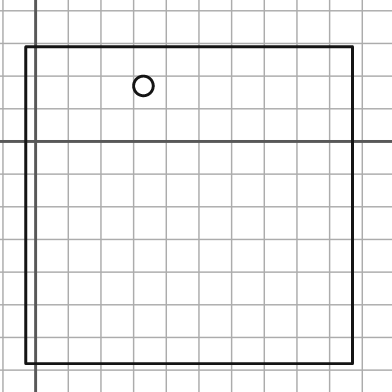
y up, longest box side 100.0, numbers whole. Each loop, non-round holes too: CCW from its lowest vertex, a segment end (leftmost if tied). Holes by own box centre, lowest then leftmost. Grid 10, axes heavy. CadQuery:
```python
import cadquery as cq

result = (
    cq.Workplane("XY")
    .moveTo(-3.0, -68.0)
    .lineTo(97.0, -68.0)
    .lineTo(97.0, 29.0)
    .lineTo(-3.0, 29.0)
    .close()
    .moveTo(33.0, 17.0)
    .circle(3.0)
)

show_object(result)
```